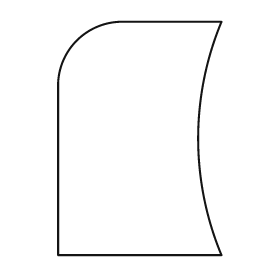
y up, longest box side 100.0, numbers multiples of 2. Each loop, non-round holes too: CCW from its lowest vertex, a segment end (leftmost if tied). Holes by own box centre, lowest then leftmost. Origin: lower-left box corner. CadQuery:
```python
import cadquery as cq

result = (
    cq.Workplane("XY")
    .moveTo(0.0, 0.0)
    .lineTo(70.0, 0.0)
    .threePointArc((60.0, 50.0), (70.0, 100.0))
    .lineTo(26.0, 100.0)
    .threePointArc((8.0, 92.0), (0.0, 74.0))
    .close()
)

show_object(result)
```